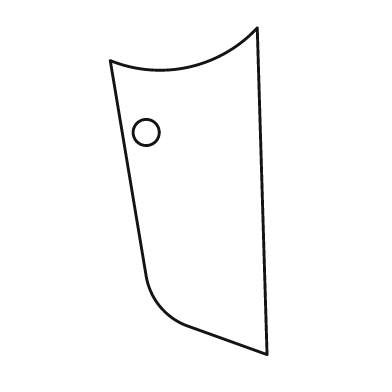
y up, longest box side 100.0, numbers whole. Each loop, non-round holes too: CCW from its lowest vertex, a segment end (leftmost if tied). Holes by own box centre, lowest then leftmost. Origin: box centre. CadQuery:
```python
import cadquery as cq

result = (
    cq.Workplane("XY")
    .moveTo(24.0, -50.0)
    .lineTo(21.0, 50.0)
    .threePointArc((0.0, 38.0), (-24.0, 40.0))
    .lineTo(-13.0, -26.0)
    .threePointArc((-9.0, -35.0), (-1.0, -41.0))
    .close()
    .moveTo(-13.0, 18.0)
    .circle(4.0)
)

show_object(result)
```